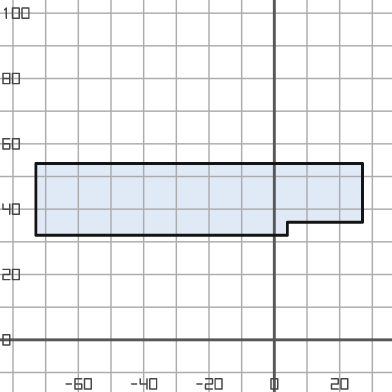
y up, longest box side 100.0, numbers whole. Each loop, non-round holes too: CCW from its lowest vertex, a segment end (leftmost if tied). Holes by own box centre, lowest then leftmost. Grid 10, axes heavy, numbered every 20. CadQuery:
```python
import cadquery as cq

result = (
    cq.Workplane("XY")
    .moveTo(-73.0, 32.0)
    .lineTo(4.0, 32.0)
    .lineTo(4.0, 36.0)
    .lineTo(27.0, 36.0)
    .lineTo(27.0, 54.0)
    .lineTo(-73.0, 54.0)
    .close()
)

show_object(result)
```